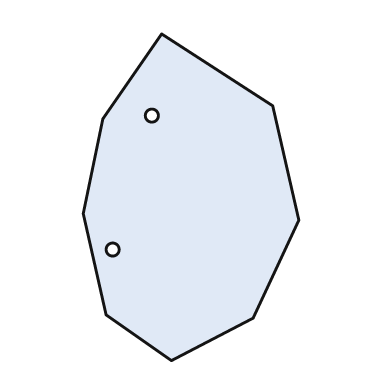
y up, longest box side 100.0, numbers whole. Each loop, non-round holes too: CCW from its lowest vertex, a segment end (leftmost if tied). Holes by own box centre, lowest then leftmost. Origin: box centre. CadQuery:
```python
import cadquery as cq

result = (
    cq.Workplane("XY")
    .moveTo(-6.0, -50.0)
    .lineTo(19.0, -37.0)
    .lineTo(33.0, -7.0)
    .lineTo(25.0, 28.0)
    .lineTo(-9.0, 50.0)
    .lineTo(-27.0, 24.0)
    .lineTo(-33.0, -5.0)
    .lineTo(-26.0, -36.0)
    .close()
    .moveTo(-24.0, -16.0)
    .circle(2.0)
    .moveTo(-12.0, 25.0)
    .circle(2.0)
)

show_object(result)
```